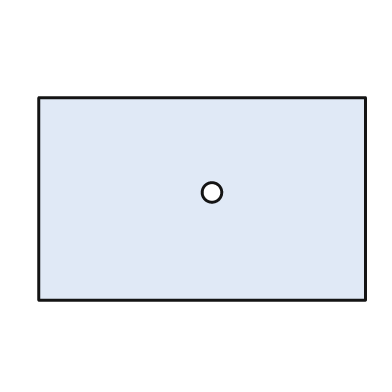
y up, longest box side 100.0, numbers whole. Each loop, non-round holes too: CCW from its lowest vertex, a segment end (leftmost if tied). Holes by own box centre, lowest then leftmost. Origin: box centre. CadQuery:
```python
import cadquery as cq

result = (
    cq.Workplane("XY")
    .moveTo(-50.0, -31.0)
    .lineTo(50.0, -31.0)
    .lineTo(50.0, 31.0)
    .lineTo(-50.0, 31.0)
    .close()
    .moveTo(3.0, 2.0)
    .circle(3.0)
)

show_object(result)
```